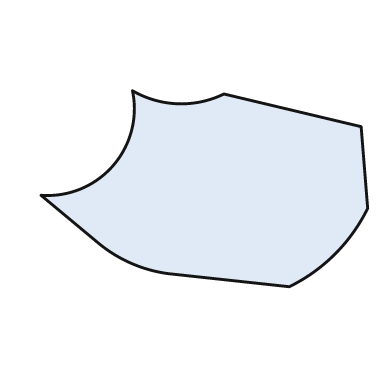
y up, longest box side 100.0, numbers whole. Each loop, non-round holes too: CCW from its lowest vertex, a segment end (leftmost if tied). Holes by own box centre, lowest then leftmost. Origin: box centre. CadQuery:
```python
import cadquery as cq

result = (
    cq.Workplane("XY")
    .moveTo(26.0, -30.0)
    .threePointArc((40.0, -20.0), (50.0, -6.0))
    .lineTo(48.0, 19.0)
    .lineTo(6.0, 29.0)
    .threePointArc((-8.0, 26.0), (-22.0, 30.0))
    .threePointArc((-28.0, 7.0), (-50.0, -2.0))
    .lineTo(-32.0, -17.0)
    .threePointArc((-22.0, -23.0), (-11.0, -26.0))
    .close()
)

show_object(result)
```